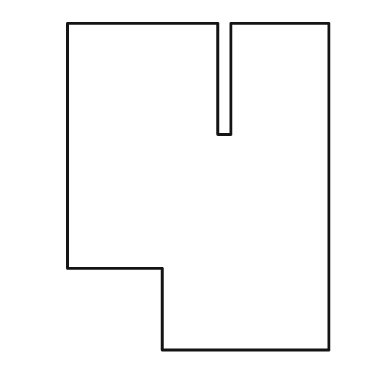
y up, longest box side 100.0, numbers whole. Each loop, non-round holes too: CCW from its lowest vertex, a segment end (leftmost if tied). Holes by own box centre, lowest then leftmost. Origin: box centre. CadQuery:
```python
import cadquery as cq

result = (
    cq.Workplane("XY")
    .moveTo(-11.0, -50.0)
    .lineTo(40.0, -50.0)
    .lineTo(40.0, 50.0)
    .lineTo(10.0, 50.0)
    .lineTo(10.0, 16.0)
    .lineTo(6.0, 16.0)
    .lineTo(6.0, 50.0)
    .lineTo(-40.0, 50.0)
    .lineTo(-40.0, -25.0)
    .lineTo(-11.0, -25.0)
    .close()
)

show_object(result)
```